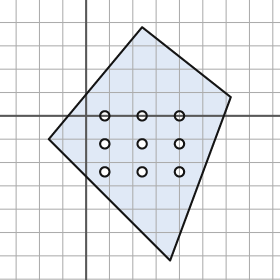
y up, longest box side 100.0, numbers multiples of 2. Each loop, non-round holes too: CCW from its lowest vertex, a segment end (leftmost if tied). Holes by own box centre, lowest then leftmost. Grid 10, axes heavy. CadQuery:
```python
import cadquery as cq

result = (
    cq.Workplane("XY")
    .moveTo(36.0, -62.0)
    .lineTo(62.0, 8.0)
    .lineTo(24.0, 38.0)
    .lineTo(-16.0, -10.0)
    .close()
    .moveTo(8.0, -24.0)
    .circle(2.0)
    .moveTo(24.0, -24.0)
    .circle(2.0)
    .moveTo(40.0, -24.0)
    .circle(2.0)
    .moveTo(8.0, -12.0)
    .circle(2.0)
    .moveTo(24.0, -12.0)
    .circle(2.0)
    .moveTo(40.0, -12.0)
    .circle(2.0)
    .moveTo(8.0, 0.0)
    .circle(2.0)
    .moveTo(24.0, 0.0)
    .circle(2.0)
    .moveTo(40.0, 0.0)
    .circle(2.0)
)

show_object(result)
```